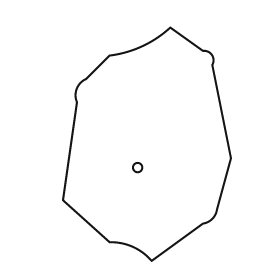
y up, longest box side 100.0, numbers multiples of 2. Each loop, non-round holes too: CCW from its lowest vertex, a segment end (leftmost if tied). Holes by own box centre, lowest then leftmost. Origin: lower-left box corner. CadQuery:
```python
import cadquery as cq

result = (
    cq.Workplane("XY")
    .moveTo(38.0, 0.0)
    .lineTo(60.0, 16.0)
    .threePointArc((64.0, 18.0), (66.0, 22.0))
    .lineTo(72.0, 44.0)
    .lineTo(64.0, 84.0)
    .threePointArc((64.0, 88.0), (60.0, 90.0))
    .lineTo(46.0, 100.0)
    .threePointArc((34.0, 92.0), (20.0, 88.0))
    .lineTo(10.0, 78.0)
    .threePointArc((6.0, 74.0), (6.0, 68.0))
    .lineTo(0.0, 26.0)
    .lineTo(20.0, 8.0)
    .threePointArc((30.0, 6.0), (38.0, 0.0))
    .close()
    .moveTo(32.0, 40.0)
    .circle(2.0)
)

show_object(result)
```